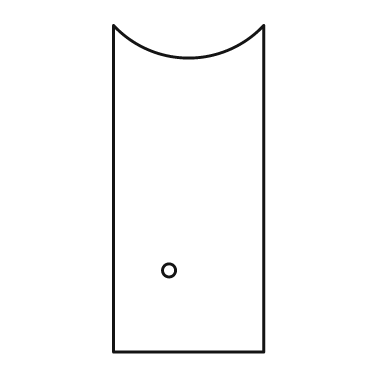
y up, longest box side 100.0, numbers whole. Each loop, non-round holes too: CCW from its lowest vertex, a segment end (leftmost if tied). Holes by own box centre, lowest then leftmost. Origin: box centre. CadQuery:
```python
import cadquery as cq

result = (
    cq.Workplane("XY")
    .moveTo(-23.0, -50.0)
    .lineTo(23.0, -50.0)
    .lineTo(23.0, 50.0)
    .threePointArc((0.0, 40.0), (-23.0, 50.0))
    .close()
    .moveTo(-6.0, -25.0)
    .circle(2.0)
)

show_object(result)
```